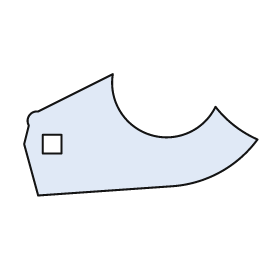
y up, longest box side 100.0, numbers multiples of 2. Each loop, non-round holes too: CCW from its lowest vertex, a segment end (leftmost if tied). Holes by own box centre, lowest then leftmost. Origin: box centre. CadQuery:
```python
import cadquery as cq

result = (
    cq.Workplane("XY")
    .moveTo(-44.0, -26.0)
    .lineTo(14.0, -22.0)
    .threePointArc((34.0, -16.0), (50.0, -2.0))
    .threePointArc((40.0, 4.0), (32.0, 12.0))
    .threePointArc((4.0, 0.0), (-12.0, 26.0))
    .lineTo(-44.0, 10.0)
    .threePointArc((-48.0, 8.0), (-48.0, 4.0))
    .lineTo(-50.0, -4.0)
    .close()
    .moveTo(-42.0, -8.0)
    .lineTo(-34.0, -8.0)
    .lineTo(-34.0, 0.0)
    .lineTo(-42.0, 0.0)
    .close()
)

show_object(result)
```